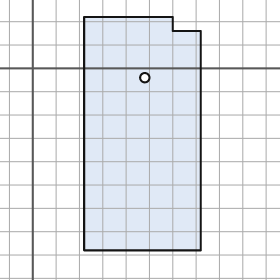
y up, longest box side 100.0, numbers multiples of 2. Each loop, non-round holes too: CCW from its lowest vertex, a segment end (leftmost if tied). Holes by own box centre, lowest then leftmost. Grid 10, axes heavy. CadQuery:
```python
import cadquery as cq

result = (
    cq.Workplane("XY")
    .moveTo(22.0, -78.0)
    .lineTo(72.0, -78.0)
    .lineTo(72.0, 16.0)
    .lineTo(60.0, 16.0)
    .lineTo(60.0, 22.0)
    .lineTo(22.0, 22.0)
    .close()
    .moveTo(48.0, -4.0)
    .circle(2.0)
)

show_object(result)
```